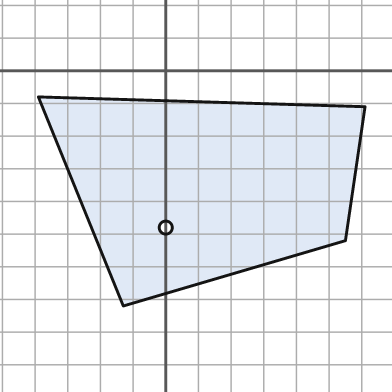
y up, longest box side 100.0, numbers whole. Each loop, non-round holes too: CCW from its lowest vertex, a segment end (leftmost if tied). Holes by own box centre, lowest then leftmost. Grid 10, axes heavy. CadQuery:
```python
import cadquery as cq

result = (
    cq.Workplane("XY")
    .moveTo(-13.0, -72.0)
    .lineTo(55.0, -52.0)
    .lineTo(61.0, -11.0)
    .lineTo(-39.0, -8.0)
    .close()
    .moveTo(0.0, -48.0)
    .circle(2.0)
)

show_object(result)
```